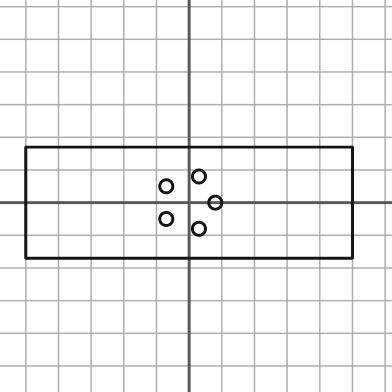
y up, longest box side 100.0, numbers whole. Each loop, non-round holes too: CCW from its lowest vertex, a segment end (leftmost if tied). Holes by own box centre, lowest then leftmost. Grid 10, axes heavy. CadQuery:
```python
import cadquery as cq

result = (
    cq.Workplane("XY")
    .moveTo(-50.0, -17.0)
    .lineTo(50.0, -17.0)
    .lineTo(50.0, 17.0)
    .lineTo(-50.0, 17.0)
    .close()
    .moveTo(3.0, -8.0)
    .circle(2.0)
    .moveTo(-7.0, -5.0)
    .circle(2.0)
    .moveTo(8.0, 0.0)
    .circle(2.0)
    .moveTo(-7.0, 5.0)
    .circle(2.0)
    .moveTo(3.0, 8.0)
    .circle(2.0)
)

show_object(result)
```